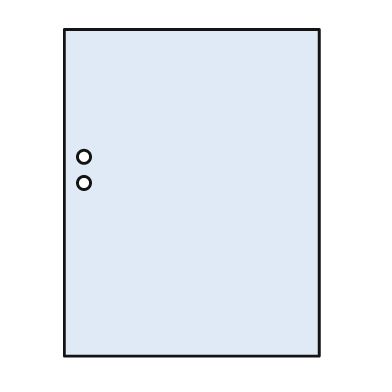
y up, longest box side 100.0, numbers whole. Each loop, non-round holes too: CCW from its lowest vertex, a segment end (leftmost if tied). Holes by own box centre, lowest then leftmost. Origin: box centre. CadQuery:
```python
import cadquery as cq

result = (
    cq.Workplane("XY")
    .moveTo(-39.0, -50.0)
    .lineTo(39.0, -50.0)
    .lineTo(39.0, 50.0)
    .lineTo(-39.0, 50.0)
    .close()
    .moveTo(-33.0, 3.0)
    .circle(2.0)
    .moveTo(-33.0, 11.0)
    .circle(2.0)
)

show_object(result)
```